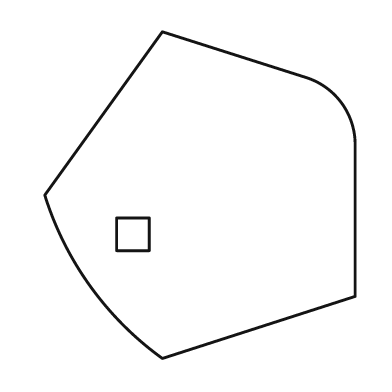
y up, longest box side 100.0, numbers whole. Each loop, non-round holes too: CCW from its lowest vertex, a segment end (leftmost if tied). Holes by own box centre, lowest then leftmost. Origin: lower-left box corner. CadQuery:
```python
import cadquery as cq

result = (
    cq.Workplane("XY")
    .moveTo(36.0, 0.0)
    .lineTo(95.0, 19.0)
    .lineTo(95.0, 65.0)
    .threePointArc((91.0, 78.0), (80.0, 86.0))
    .lineTo(36.0, 100.0)
    .lineTo(0.0, 50.0)
    .threePointArc((14.0, 22.0), (36.0, 0.0))
    .close()
    .moveTo(22.0, 33.0)
    .lineTo(32.0, 33.0)
    .lineTo(32.0, 43.0)
    .lineTo(22.0, 43.0)
    .close()
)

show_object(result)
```